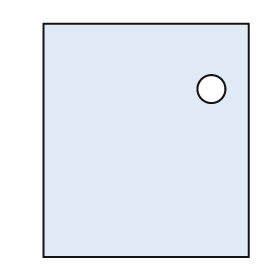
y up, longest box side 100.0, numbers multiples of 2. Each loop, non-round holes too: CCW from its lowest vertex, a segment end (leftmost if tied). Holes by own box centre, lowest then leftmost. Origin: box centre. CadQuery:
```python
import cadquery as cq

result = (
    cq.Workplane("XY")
    .moveTo(-44.0, -50.0)
    .lineTo(44.0, -50.0)
    .lineTo(44.0, 50.0)
    .lineTo(-44.0, 50.0)
    .close()
    .moveTo(28.0, 22.0)
    .circle(6.0)
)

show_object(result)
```